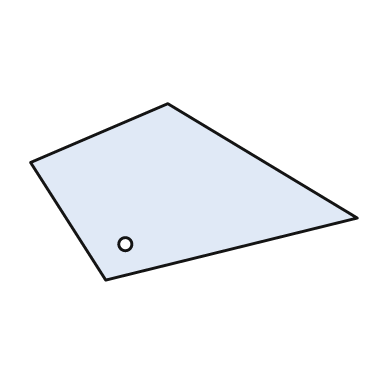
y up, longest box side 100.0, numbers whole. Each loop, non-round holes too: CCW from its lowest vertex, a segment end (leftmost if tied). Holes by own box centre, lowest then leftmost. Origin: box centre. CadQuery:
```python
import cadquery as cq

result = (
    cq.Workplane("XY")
    .moveTo(-27.0, -27.0)
    .lineTo(50.0, -8.0)
    .lineTo(-8.0, 27.0)
    .lineTo(-50.0, 9.0)
    .close()
    .moveTo(-21.0, -16.0)
    .circle(2.0)
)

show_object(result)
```